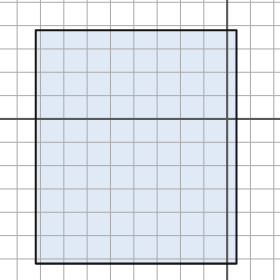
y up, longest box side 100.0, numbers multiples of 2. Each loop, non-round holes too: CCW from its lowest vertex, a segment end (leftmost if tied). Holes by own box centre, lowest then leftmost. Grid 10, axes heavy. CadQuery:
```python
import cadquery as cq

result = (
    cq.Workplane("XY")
    .moveTo(-82.0, -62.0)
    .lineTo(4.0, -62.0)
    .lineTo(4.0, 38.0)
    .lineTo(-82.0, 38.0)
    .close()
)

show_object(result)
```